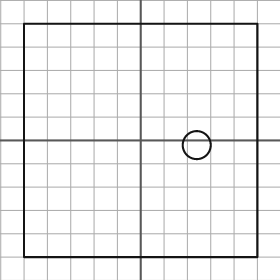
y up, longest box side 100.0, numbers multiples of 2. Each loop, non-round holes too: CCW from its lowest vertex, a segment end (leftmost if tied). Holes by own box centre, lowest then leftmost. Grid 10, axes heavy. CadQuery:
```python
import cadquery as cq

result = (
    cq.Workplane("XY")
    .moveTo(-50.0, -50.0)
    .lineTo(50.0, -50.0)
    .lineTo(50.0, 50.0)
    .lineTo(-50.0, 50.0)
    .close()
    .moveTo(24.0, -2.0)
    .circle(6.0)
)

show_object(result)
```